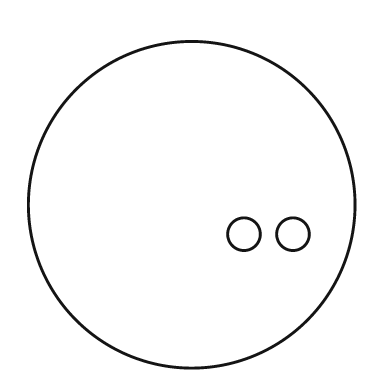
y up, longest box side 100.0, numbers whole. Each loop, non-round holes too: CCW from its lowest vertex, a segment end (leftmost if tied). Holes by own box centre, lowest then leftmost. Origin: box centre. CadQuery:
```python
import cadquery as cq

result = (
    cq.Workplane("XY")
    .moveTo(0.0, 0.0)
    .circle(50.0)
    .moveTo(16.0, -9.0)
    .circle(5.0)
    .moveTo(31.0, -9.0)
    .circle(5.0)
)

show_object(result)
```